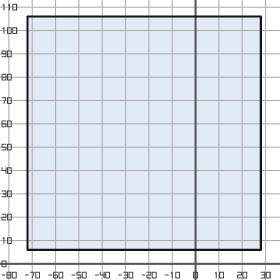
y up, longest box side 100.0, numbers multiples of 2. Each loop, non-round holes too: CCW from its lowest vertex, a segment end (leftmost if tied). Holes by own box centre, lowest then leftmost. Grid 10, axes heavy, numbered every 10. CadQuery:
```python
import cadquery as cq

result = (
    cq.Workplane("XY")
    .moveTo(-72.0, 6.0)
    .lineTo(28.0, 6.0)
    .lineTo(28.0, 106.0)
    .lineTo(-72.0, 106.0)
    .close()
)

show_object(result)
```